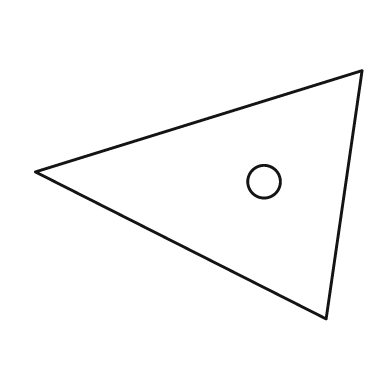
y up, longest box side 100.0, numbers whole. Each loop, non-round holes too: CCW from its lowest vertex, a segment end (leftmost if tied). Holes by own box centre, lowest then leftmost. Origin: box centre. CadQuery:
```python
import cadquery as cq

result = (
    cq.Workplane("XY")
    .moveTo(39.0, -38.0)
    .lineTo(50.0, 38.0)
    .lineTo(-50.0, 7.0)
    .close()
    .moveTo(20.0, 4.0)
    .circle(5.0)
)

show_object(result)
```